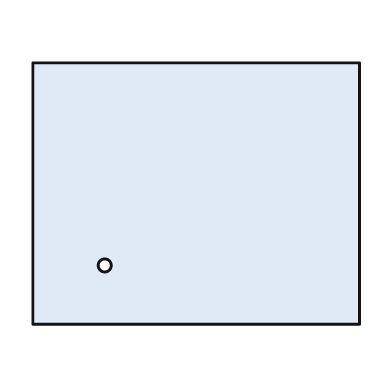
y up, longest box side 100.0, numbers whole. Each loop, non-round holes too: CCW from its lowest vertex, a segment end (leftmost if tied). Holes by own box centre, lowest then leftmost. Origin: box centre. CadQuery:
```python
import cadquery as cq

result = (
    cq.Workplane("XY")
    .moveTo(-50.0, -40.0)
    .lineTo(50.0, -40.0)
    .lineTo(50.0, 40.0)
    .lineTo(-50.0, 40.0)
    .close()
    .moveTo(-28.0, -22.0)
    .circle(2.0)
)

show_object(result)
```